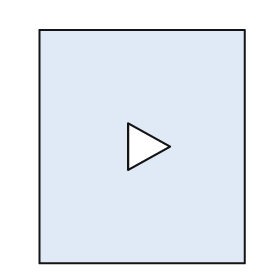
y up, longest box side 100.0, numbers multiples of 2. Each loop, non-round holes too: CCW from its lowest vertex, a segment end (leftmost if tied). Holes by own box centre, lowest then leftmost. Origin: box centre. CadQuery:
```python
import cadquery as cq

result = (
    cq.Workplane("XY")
    .moveTo(-44.0, -50.0)
    .lineTo(44.0, -50.0)
    .lineTo(44.0, 50.0)
    .lineTo(-44.0, 50.0)
    .close()
    .moveTo(-6.0, -10.0)
    .lineTo(12.0, 0.0)
    .lineTo(-6.0, 10.0)
    .close()
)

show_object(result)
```